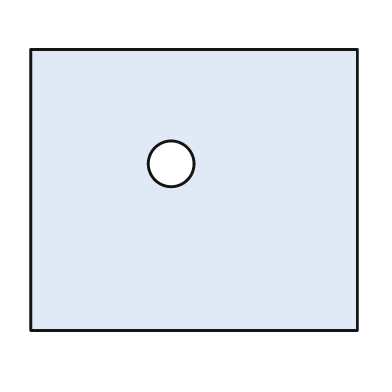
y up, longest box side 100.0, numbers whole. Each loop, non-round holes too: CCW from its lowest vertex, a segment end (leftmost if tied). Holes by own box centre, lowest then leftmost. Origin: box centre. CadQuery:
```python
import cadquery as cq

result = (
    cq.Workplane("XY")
    .moveTo(-50.0, -43.0)
    .lineTo(50.0, -43.0)
    .lineTo(50.0, 43.0)
    .lineTo(-50.0, 43.0)
    .close()
    .moveTo(-7.0, 8.0)
    .circle(7.0)
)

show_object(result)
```